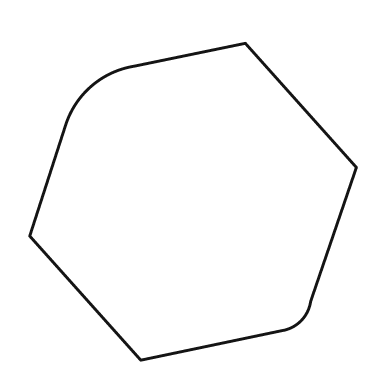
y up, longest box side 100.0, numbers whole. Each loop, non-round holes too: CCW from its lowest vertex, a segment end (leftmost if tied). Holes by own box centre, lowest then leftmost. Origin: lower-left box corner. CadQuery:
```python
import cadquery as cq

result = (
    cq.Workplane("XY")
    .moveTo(34.0, 0.0)
    .lineTo(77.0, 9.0)
    .threePointArc((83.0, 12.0), (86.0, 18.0))
    .lineTo(100.0, 59.0)
    .lineTo(66.0, 97.0)
    .lineTo(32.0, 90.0)
    .threePointArc((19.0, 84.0), (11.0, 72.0))
    .lineTo(0.0, 38.0)
    .close()
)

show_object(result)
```